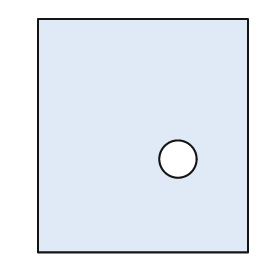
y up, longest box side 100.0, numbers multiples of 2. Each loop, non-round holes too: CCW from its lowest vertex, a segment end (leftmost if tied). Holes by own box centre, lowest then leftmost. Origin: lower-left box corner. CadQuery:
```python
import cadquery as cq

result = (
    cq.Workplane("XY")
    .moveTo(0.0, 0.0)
    .lineTo(90.0, 0.0)
    .lineTo(90.0, 100.0)
    .lineTo(0.0, 100.0)
    .close()
    .moveTo(60.0, 40.0)
    .circle(8.0)
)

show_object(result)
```